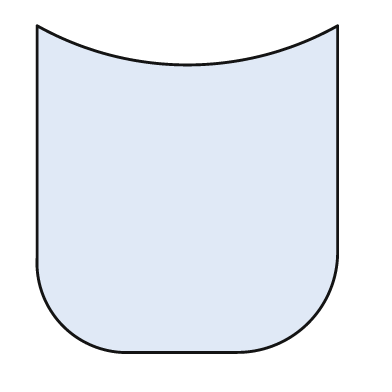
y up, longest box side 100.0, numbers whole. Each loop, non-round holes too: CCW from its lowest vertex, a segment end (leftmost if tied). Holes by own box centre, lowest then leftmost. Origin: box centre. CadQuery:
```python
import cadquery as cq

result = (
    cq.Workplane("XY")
    .moveTo(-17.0, -50.0)
    .lineTo(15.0, -50.0)
    .threePointArc((37.0, -41.0), (46.0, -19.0))
    .lineTo(46.0, 50.0)
    .threePointArc((0.0, 38.0), (-46.0, 50.0))
    .lineTo(-46.0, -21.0)
    .threePointArc((-38.0, -42.0), (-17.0, -50.0))
    .close()
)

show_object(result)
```